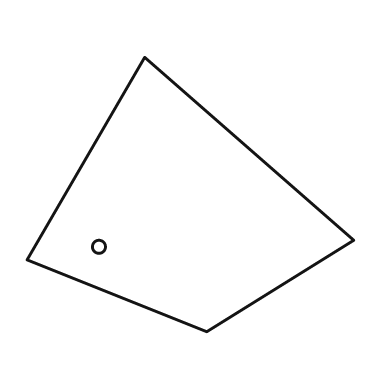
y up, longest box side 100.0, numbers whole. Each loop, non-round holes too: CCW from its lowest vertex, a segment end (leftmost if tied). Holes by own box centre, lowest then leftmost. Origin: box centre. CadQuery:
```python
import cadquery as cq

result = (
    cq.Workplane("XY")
    .moveTo(5.0, -42.0)
    .lineTo(50.0, -14.0)
    .lineTo(-14.0, 42.0)
    .lineTo(-50.0, -20.0)
    .close()
    .moveTo(-28.0, -16.0)
    .circle(2.0)
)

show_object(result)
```